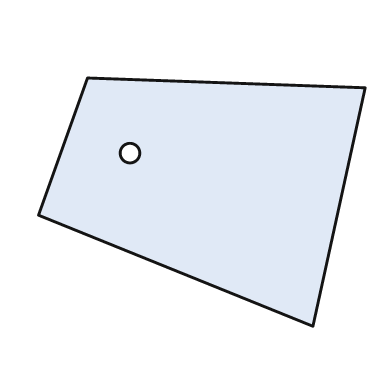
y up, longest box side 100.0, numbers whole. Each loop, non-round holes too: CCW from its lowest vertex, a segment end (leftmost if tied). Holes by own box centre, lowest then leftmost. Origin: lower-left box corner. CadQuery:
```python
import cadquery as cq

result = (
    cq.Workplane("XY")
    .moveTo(84.0, 0.0)
    .lineTo(100.0, 73.0)
    .lineTo(15.0, 76.0)
    .lineTo(0.0, 34.0)
    .close()
    .moveTo(28.0, 53.0)
    .circle(3.0)
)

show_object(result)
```